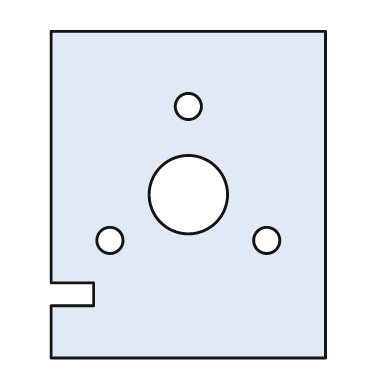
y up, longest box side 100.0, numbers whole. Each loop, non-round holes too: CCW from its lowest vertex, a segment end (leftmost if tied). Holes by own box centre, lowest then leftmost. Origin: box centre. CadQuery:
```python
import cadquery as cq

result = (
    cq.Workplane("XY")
    .moveTo(-42.0, -50.0)
    .lineTo(42.0, -50.0)
    .lineTo(42.0, 50.0)
    .lineTo(-42.0, 50.0)
    .lineTo(-42.0, -27.0)
    .lineTo(-29.0, -27.0)
    .lineTo(-29.0, -34.0)
    .lineTo(-42.0, -34.0)
    .close()
    .moveTo(-24.0, -14.0)
    .circle(4.0)
    .moveTo(24.0, -14.0)
    .circle(4.0)
    .moveTo(0.0, 0.0)
    .circle(12.0)
    .moveTo(0.0, 27.0)
    .circle(4.0)
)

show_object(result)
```